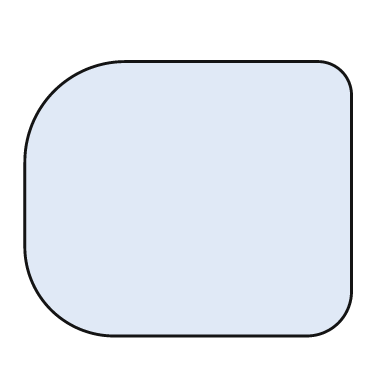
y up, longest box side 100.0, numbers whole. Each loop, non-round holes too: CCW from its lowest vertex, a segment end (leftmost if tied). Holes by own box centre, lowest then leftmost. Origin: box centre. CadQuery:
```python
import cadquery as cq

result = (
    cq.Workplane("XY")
    .moveTo(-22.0, -42.0)
    .lineTo(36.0, -42.0)
    .threePointArc((46.0, -38.0), (50.0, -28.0))
    .lineTo(50.0, 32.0)
    .threePointArc((47.0, 39.0), (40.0, 42.0))
    .lineTo(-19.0, 42.0)
    .threePointArc((-41.0, 33.0), (-50.0, 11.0))
    .lineTo(-50.0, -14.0)
    .threePointArc((-42.0, -34.0), (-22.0, -42.0))
    .close()
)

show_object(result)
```